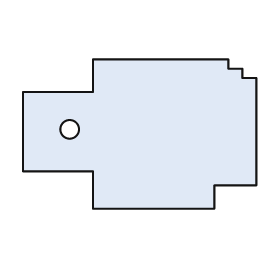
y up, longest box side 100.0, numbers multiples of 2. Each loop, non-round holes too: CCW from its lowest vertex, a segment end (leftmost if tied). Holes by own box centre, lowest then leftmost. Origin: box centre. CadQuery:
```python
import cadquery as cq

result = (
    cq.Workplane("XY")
    .moveTo(-20.0, -32.0)
    .lineTo(32.0, -32.0)
    .lineTo(32.0, -22.0)
    .lineTo(50.0, -22.0)
    .lineTo(50.0, 24.0)
    .lineTo(44.0, 24.0)
    .lineTo(44.0, 28.0)
    .lineTo(38.0, 28.0)
    .lineTo(38.0, 32.0)
    .lineTo(-20.0, 32.0)
    .lineTo(-20.0, 18.0)
    .lineTo(-50.0, 18.0)
    .lineTo(-50.0, -16.0)
    .lineTo(-20.0, -16.0)
    .close()
    .moveTo(-30.0, 2.0)
    .circle(4.0)
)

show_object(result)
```